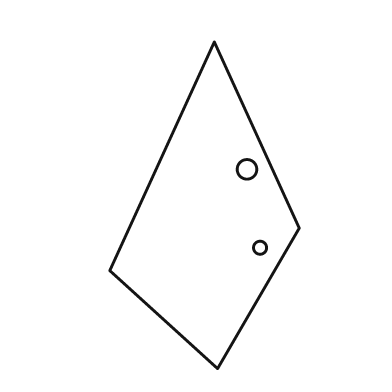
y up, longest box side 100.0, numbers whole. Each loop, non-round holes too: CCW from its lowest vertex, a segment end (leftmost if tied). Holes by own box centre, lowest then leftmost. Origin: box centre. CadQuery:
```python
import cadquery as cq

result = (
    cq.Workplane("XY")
    .moveTo(4.0, -50.0)
    .lineTo(29.0, -7.0)
    .lineTo(3.0, 50.0)
    .lineTo(-29.0, -20.0)
    .close()
    .moveTo(17.0, -13.0)
    .circle(2.0)
    .moveTo(13.0, 11.0)
    .circle(3.0)
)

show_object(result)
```